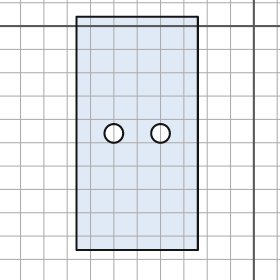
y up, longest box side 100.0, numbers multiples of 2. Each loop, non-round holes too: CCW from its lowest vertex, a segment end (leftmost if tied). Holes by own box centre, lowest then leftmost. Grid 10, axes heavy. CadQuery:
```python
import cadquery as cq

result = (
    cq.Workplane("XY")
    .moveTo(-76.0, -96.0)
    .lineTo(-24.0, -96.0)
    .lineTo(-24.0, 4.0)
    .lineTo(-76.0, 4.0)
    .close()
    .moveTo(-60.0, -46.0)
    .circle(4.0)
    .moveTo(-40.0, -46.0)
    .circle(4.0)
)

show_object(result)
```